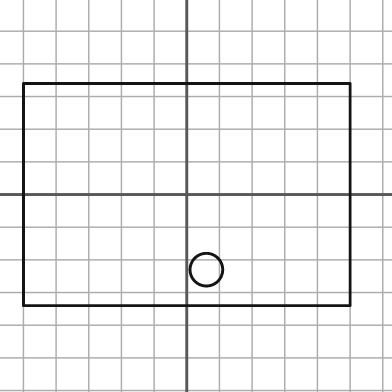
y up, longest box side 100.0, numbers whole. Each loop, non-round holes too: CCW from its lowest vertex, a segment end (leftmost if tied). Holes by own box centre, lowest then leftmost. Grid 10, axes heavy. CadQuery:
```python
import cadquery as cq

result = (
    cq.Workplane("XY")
    .moveTo(-50.0, -34.0)
    .lineTo(50.0, -34.0)
    .lineTo(50.0, 34.0)
    .lineTo(-50.0, 34.0)
    .close()
    .moveTo(6.0, -23.0)
    .circle(5.0)
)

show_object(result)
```